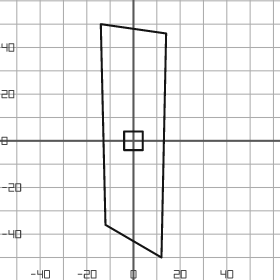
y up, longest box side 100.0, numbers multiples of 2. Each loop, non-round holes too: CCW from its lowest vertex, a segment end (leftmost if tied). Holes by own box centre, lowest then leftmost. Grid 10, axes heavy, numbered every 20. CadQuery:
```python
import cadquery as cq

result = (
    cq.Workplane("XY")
    .moveTo(12.0, -50.0)
    .lineTo(14.0, 46.0)
    .lineTo(-14.0, 50.0)
    .lineTo(-12.0, -36.0)
    .close()
    .moveTo(-4.0, -4.0)
    .lineTo(4.0, -4.0)
    .lineTo(4.0, 4.0)
    .lineTo(-4.0, 4.0)
    .close()
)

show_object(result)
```